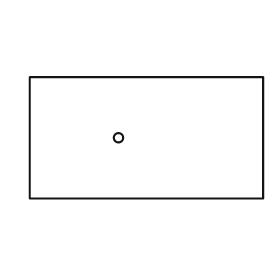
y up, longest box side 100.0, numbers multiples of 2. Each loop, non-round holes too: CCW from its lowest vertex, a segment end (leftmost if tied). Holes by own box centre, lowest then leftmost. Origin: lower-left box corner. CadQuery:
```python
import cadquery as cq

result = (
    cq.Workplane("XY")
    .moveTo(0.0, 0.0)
    .lineTo(100.0, 0.0)
    .lineTo(100.0, 52.0)
    .lineTo(0.0, 52.0)
    .close()
    .moveTo(38.0, 26.0)
    .circle(2.0)
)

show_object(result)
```